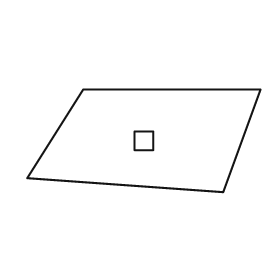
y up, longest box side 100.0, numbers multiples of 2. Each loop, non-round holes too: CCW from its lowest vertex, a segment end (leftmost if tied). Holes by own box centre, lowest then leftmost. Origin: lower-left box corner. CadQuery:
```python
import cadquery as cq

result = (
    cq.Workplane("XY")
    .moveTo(84.0, 0.0)
    .lineTo(100.0, 44.0)
    .lineTo(24.0, 44.0)
    .lineTo(0.0, 6.0)
    .close()
    .moveTo(46.0, 18.0)
    .lineTo(54.0, 18.0)
    .lineTo(54.0, 26.0)
    .lineTo(46.0, 26.0)
    .close()
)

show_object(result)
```